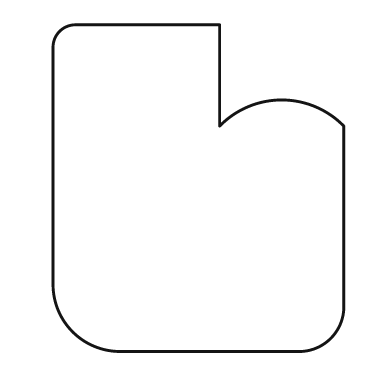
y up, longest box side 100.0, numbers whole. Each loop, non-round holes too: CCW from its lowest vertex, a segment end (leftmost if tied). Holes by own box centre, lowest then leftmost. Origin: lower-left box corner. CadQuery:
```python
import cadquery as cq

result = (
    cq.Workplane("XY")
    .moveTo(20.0, 0.0)
    .lineTo(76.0, 0.0)
    .threePointArc((85.0, 4.0), (89.0, 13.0))
    .lineTo(89.0, 69.0)
    .threePointArc((70.0, 77.0), (51.0, 69.0))
    .lineTo(51.0, 100.0)
    .lineTo(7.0, 100.0)
    .threePointArc((2.0, 98.0), (0.0, 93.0))
    .lineTo(0.0, 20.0)
    .threePointArc((6.0, 6.0), (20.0, 0.0))
    .close()
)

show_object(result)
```